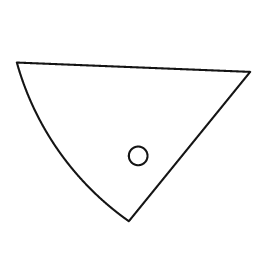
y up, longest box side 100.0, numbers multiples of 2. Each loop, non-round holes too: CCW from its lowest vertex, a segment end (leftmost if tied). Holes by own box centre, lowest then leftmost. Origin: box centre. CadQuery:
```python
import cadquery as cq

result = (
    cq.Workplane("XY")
    .moveTo(-2.0, -34.0)
    .lineTo(50.0, 30.0)
    .lineTo(-50.0, 34.0)
    .threePointArc((-32.0, -4.0), (-2.0, -34.0))
    .close()
    .moveTo(2.0, -6.0)
    .circle(4.0)
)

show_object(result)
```